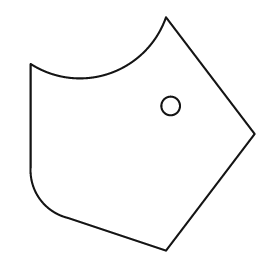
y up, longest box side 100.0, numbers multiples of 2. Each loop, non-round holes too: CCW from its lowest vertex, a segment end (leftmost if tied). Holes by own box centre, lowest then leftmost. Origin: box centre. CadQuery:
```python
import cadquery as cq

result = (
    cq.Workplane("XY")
    .moveTo(10.0, -50.0)
    .lineTo(48.0, 0.0)
    .lineTo(10.0, 50.0)
    .threePointArc((-14.0, 26.0), (-48.0, 30.0))
    .lineTo(-48.0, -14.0)
    .threePointArc((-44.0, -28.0), (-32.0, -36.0))
    .close()
    .moveTo(12.0, 12.0)
    .circle(4.0)
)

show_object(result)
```